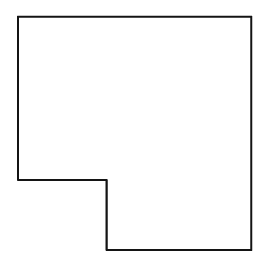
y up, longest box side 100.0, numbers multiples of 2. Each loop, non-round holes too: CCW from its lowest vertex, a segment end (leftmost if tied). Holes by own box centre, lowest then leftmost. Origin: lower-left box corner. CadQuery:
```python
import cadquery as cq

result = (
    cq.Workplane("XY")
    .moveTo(38.0, 0.0)
    .lineTo(100.0, 0.0)
    .lineTo(100.0, 100.0)
    .lineTo(0.0, 100.0)
    .lineTo(0.0, 30.0)
    .lineTo(38.0, 30.0)
    .close()
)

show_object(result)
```